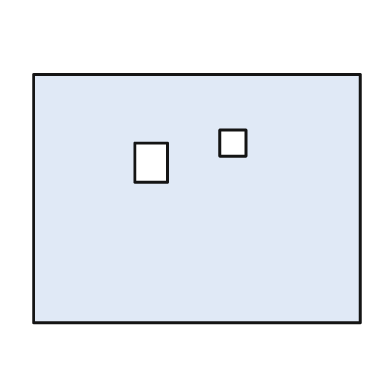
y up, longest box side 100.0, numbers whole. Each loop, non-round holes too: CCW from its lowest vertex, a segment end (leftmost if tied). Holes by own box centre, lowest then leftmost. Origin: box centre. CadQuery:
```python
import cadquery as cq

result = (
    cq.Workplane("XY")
    .moveTo(-50.0, -38.0)
    .lineTo(50.0, -38.0)
    .lineTo(50.0, 38.0)
    .lineTo(-50.0, 38.0)
    .close()
    .moveTo(-19.0, 5.0)
    .lineTo(-9.0, 5.0)
    .lineTo(-9.0, 17.0)
    .lineTo(-19.0, 17.0)
    .close()
    .moveTo(7.0, 13.0)
    .lineTo(15.0, 13.0)
    .lineTo(15.0, 21.0)
    .lineTo(7.0, 21.0)
    .close()
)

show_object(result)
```